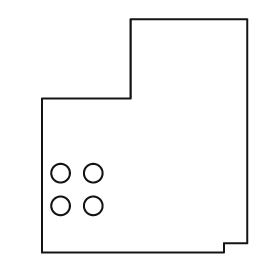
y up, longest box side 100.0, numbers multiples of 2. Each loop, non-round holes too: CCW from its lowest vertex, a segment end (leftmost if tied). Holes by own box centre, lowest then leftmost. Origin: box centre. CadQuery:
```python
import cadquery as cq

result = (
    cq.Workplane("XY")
    .moveTo(-44.0, -50.0)
    .lineTo(34.0, -50.0)
    .lineTo(34.0, -46.0)
    .lineTo(44.0, -46.0)
    .lineTo(44.0, 50.0)
    .lineTo(-6.0, 50.0)
    .lineTo(-6.0, 16.0)
    .lineTo(-44.0, 16.0)
    .close()
    .moveTo(-36.0, -30.0)
    .circle(4.0)
    .moveTo(-22.0, -30.0)
    .circle(4.0)
    .moveTo(-36.0, -16.0)
    .circle(4.0)
    .moveTo(-22.0, -16.0)
    .circle(4.0)
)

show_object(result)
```